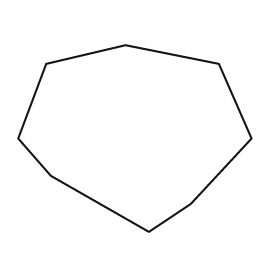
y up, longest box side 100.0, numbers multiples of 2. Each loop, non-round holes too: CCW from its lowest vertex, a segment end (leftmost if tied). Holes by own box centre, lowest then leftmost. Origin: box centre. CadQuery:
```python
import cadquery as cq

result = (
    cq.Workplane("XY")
    .moveTo(6.0, -40.0)
    .lineTo(24.0, -28.0)
    .lineTo(50.0, 0.0)
    .lineTo(36.0, 32.0)
    .lineTo(-4.0, 40.0)
    .lineTo(-38.0, 32.0)
    .lineTo(-50.0, 0.0)
    .lineTo(-36.0, -16.0)
    .close()
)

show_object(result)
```